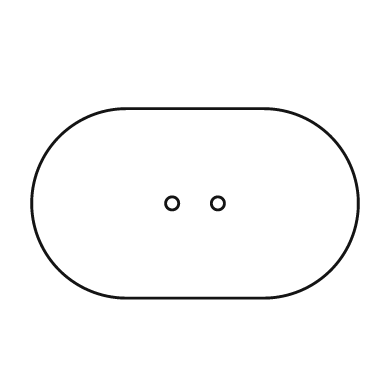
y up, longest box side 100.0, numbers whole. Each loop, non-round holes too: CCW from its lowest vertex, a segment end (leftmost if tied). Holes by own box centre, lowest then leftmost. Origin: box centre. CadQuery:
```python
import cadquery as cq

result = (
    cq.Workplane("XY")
    .moveTo(-21.0, -29.0)
    .lineTo(21.0, -29.0)
    .threePointArc((50.0, 0.0), (21.0, 29.0))
    .lineTo(-21.0, 29.0)
    .threePointArc((-50.0, 0.0), (-21.0, -29.0))
    .close()
    .moveTo(-7.0, 0.0)
    .circle(2.0)
    .moveTo(7.0, 0.0)
    .circle(2.0)
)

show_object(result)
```